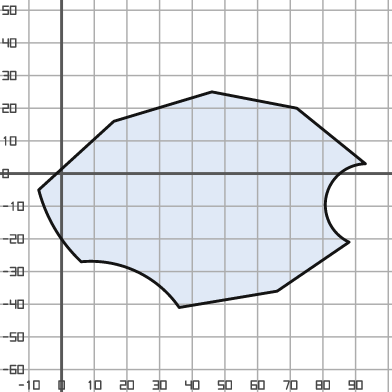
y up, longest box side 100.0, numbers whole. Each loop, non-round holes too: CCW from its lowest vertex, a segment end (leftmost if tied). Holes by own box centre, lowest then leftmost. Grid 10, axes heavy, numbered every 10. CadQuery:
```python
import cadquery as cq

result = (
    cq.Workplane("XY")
    .moveTo(36.0, -41.0)
    .lineTo(66.0, -36.0)
    .lineTo(88.0, -21.0)
    .threePointArc((81.0, -7.0), (93.0, 3.0))
    .lineTo(72.0, 20.0)
    .lineTo(46.0, 25.0)
    .lineTo(16.0, 16.0)
    .lineTo(-7.0, -5.0)
    .threePointArc((-2.0, -17.0), (6.0, -27.0))
    .threePointArc((23.0, -30.0), (36.0, -41.0))
    .close()
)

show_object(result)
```